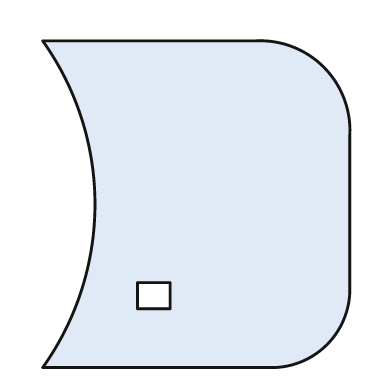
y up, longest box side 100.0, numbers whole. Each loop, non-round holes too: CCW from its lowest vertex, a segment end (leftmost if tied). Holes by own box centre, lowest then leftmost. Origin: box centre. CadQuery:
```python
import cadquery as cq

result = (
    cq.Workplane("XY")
    .moveTo(-47.0, -50.0)
    .lineTo(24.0, -50.0)
    .threePointArc((40.0, -43.0), (47.0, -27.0))
    .lineTo(47.0, 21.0)
    .threePointArc((39.0, 42.0), (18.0, 50.0))
    .lineTo(-47.0, 50.0)
    .threePointArc((-31.0, 0.0), (-47.0, -50.0))
    .close()
    .moveTo(-18.0, -32.0)
    .lineTo(-8.0, -32.0)
    .lineTo(-8.0, -24.0)
    .lineTo(-18.0, -24.0)
    .close()
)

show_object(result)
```